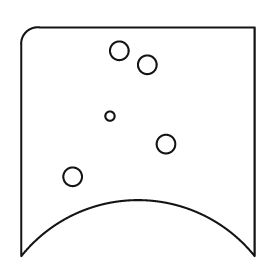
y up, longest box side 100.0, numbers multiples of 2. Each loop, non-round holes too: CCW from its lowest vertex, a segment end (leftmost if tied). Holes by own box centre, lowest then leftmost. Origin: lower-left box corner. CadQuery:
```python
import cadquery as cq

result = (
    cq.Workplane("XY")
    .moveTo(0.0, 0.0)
    .threePointArc((50.0, 24.0), (100.0, 0.0))
    .lineTo(100.0, 98.0)
    .lineTo(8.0, 98.0)
    .threePointArc((2.0, 96.0), (0.0, 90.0))
    .close()
    .moveTo(22.0, 34.0)
    .circle(4.0)
    .moveTo(62.0, 48.0)
    .circle(4.0)
    .moveTo(38.0, 60.0)
    .circle(2.0)
    .moveTo(54.0, 82.0)
    .circle(4.0)
    .moveTo(42.0, 88.0)
    .circle(4.0)
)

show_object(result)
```